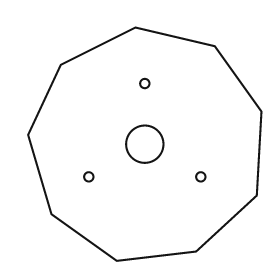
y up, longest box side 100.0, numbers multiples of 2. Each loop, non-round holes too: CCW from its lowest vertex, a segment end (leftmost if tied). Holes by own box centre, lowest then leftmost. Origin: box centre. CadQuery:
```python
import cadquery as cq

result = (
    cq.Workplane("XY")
    .moveTo(-12.0, -50.0)
    .lineTo(22.0, -46.0)
    .lineTo(48.0, -22.0)
    .lineTo(50.0, 14.0)
    .lineTo(30.0, 42.0)
    .lineTo(-4.0, 50.0)
    .lineTo(-36.0, 34.0)
    .lineTo(-50.0, 4.0)
    .lineTo(-40.0, -30.0)
    .close()
    .moveTo(-24.0, -14.0)
    .circle(2.0)
    .moveTo(24.0, -14.0)
    .circle(2.0)
    .moveTo(0.0, 0.0)
    .circle(8.0)
    .moveTo(0.0, 26.0)
    .circle(2.0)
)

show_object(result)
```